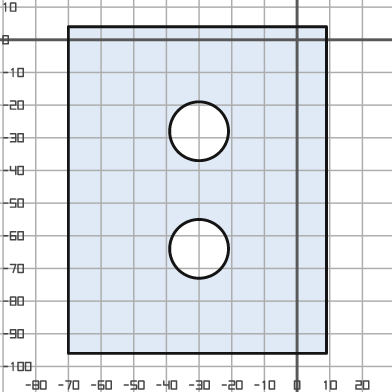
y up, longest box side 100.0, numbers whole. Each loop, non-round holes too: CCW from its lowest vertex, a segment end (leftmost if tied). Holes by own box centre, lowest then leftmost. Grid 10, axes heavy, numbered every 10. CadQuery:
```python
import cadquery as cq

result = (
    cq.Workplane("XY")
    .moveTo(-70.0, -96.0)
    .lineTo(9.0, -96.0)
    .lineTo(9.0, 4.0)
    .lineTo(-70.0, 4.0)
    .close()
    .moveTo(-30.0, -64.0)
    .circle(9.0)
    .moveTo(-30.0, -28.0)
    .circle(9.0)
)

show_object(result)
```